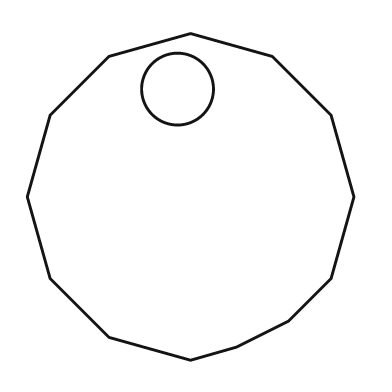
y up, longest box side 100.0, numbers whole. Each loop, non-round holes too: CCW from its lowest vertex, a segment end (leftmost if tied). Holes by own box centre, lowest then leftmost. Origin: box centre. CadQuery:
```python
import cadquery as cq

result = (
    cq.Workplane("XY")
    .moveTo(0.0, -50.0)
    .lineTo(14.0, -46.0)
    .lineTo(30.0, -38.0)
    .lineTo(43.0, -25.0)
    .lineTo(50.0, 0.0)
    .lineTo(43.0, 25.0)
    .lineTo(25.0, 43.0)
    .lineTo(0.0, 50.0)
    .lineTo(-25.0, 43.0)
    .lineTo(-43.0, 25.0)
    .lineTo(-50.0, 0.0)
    .lineTo(-43.0, -25.0)
    .lineTo(-25.0, -43.0)
    .close()
    .moveTo(-4.0, 33.0)
    .circle(11.0)
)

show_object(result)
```